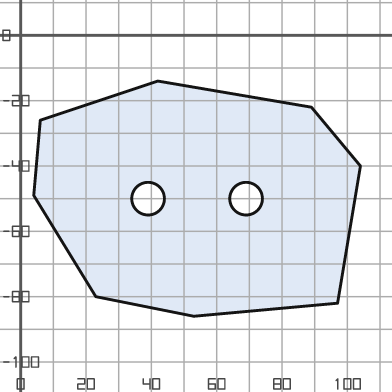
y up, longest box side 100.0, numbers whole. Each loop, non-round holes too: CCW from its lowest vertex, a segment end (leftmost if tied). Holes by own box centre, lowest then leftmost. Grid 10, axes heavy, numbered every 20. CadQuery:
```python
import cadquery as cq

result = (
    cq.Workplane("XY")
    .moveTo(53.0, -86.0)
    .lineTo(97.0, -82.0)
    .lineTo(104.0, -40.0)
    .lineTo(89.0, -22.0)
    .lineTo(42.0, -14.0)
    .lineTo(6.0, -26.0)
    .lineTo(4.0, -49.0)
    .lineTo(23.0, -80.0)
    .close()
    .moveTo(39.0, -50.0)
    .circle(5.0)
    .moveTo(69.0, -50.0)
    .circle(5.0)
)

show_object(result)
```